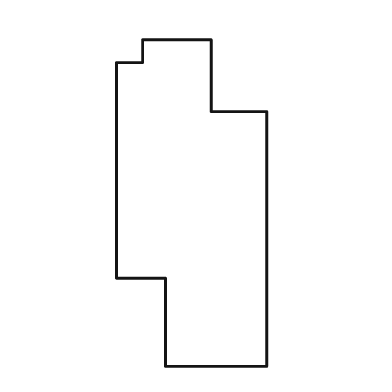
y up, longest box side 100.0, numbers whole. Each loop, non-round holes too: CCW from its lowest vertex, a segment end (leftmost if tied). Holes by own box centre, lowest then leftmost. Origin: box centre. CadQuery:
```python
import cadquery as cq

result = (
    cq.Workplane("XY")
    .moveTo(-8.0, -50.0)
    .lineTo(23.0, -50.0)
    .lineTo(23.0, 28.0)
    .lineTo(6.0, 28.0)
    .lineTo(6.0, 50.0)
    .lineTo(-15.0, 50.0)
    .lineTo(-15.0, 43.0)
    .lineTo(-23.0, 43.0)
    .lineTo(-23.0, -23.0)
    .lineTo(-8.0, -23.0)
    .close()
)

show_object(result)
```